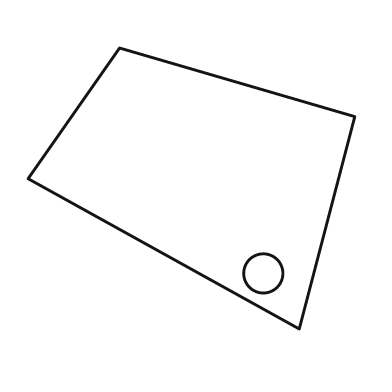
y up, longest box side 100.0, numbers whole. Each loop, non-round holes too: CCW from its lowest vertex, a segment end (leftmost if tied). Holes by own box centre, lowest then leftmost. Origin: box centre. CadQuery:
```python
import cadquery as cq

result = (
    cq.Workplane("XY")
    .moveTo(33.0, -43.0)
    .lineTo(50.0, 22.0)
    .lineTo(-22.0, 43.0)
    .lineTo(-50.0, 3.0)
    .close()
    .moveTo(22.0, -26.0)
    .circle(6.0)
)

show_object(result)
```